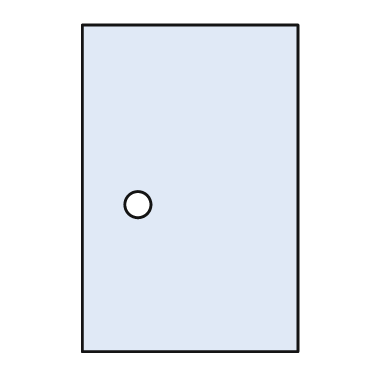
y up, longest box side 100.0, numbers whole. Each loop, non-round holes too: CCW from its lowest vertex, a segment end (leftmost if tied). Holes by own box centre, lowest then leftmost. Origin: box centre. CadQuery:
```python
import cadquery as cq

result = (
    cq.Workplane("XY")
    .moveTo(-33.0, -50.0)
    .lineTo(33.0, -50.0)
    .lineTo(33.0, 50.0)
    .lineTo(-33.0, 50.0)
    .close()
    .moveTo(-16.0, -5.0)
    .circle(4.0)
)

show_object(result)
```